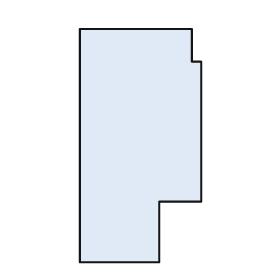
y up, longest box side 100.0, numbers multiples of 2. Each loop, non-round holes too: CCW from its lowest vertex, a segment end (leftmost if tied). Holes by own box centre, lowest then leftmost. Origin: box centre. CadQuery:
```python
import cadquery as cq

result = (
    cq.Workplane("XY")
    .moveTo(-26.0, -50.0)
    .lineTo(8.0, -50.0)
    .lineTo(8.0, -24.0)
    .lineTo(26.0, -24.0)
    .lineTo(26.0, 36.0)
    .lineTo(22.0, 36.0)
    .lineTo(22.0, 50.0)
    .lineTo(-26.0, 50.0)
    .close()
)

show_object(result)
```